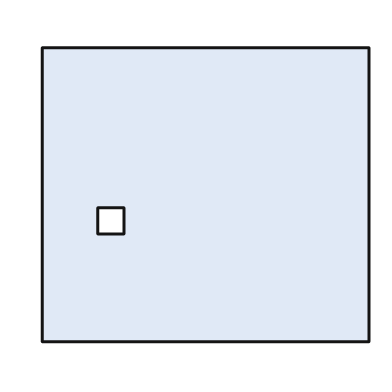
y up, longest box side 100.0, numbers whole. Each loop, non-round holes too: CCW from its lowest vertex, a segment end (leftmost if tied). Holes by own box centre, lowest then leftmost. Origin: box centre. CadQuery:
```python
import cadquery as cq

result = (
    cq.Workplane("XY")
    .moveTo(-50.0, -45.0)
    .lineTo(50.0, -45.0)
    .lineTo(50.0, 45.0)
    .lineTo(-50.0, 45.0)
    .close()
    .moveTo(-33.0, -12.0)
    .lineTo(-25.0, -12.0)
    .lineTo(-25.0, -4.0)
    .lineTo(-33.0, -4.0)
    .close()
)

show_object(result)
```